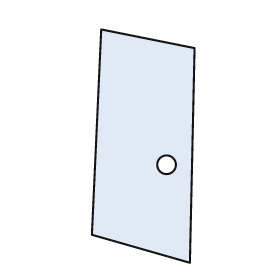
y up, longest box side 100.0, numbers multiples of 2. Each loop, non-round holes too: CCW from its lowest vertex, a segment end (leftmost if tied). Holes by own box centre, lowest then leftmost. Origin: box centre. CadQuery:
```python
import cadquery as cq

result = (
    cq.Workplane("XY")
    .moveTo(20.0, -50.0)
    .lineTo(22.0, 42.0)
    .lineTo(-18.0, 50.0)
    .lineTo(-22.0, -38.0)
    .close()
    .moveTo(10.0, -8.0)
    .circle(4.0)
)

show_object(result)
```